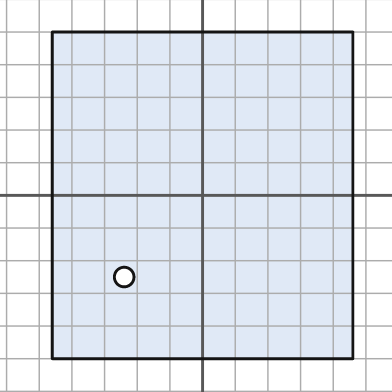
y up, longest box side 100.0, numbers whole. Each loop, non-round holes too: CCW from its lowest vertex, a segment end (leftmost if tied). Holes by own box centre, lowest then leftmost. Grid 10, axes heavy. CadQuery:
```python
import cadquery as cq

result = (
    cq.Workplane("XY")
    .moveTo(-46.0, -50.0)
    .lineTo(46.0, -50.0)
    .lineTo(46.0, 50.0)
    .lineTo(-46.0, 50.0)
    .close()
    .moveTo(-24.0, -25.0)
    .circle(3.0)
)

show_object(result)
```